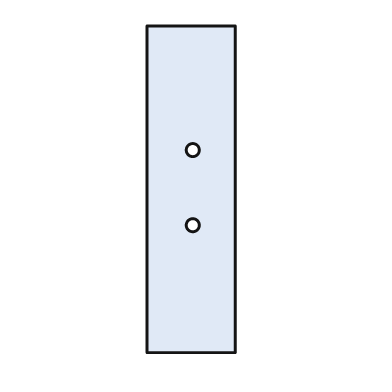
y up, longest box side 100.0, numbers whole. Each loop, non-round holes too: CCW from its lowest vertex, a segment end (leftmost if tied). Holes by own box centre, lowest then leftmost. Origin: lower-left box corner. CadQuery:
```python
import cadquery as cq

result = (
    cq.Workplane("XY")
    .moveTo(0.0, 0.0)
    .lineTo(27.0, 0.0)
    .lineTo(27.0, 100.0)
    .lineTo(0.0, 100.0)
    .close()
    .moveTo(14.0, 39.0)
    .circle(2.0)
    .moveTo(14.0, 62.0)
    .circle(2.0)
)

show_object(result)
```